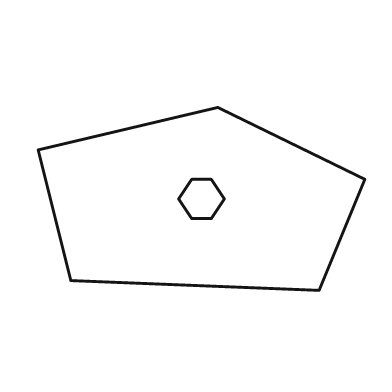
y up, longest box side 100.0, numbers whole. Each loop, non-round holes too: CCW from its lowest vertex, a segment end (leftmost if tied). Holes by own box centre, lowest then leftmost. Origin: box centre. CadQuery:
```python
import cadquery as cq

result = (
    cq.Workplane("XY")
    .moveTo(36.0, -28.0)
    .lineTo(50.0, 6.0)
    .lineTo(5.0, 28.0)
    .lineTo(-50.0, 15.0)
    .lineTo(-40.0, -25.0)
    .close()
    .moveTo(-3.0, -6.0)
    .lineTo(3.0, -6.0)
    .lineTo(7.0, 0.0)
    .lineTo(3.0, 6.0)
    .lineTo(-3.0, 6.0)
    .lineTo(-7.0, 0.0)
    .close()
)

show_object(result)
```